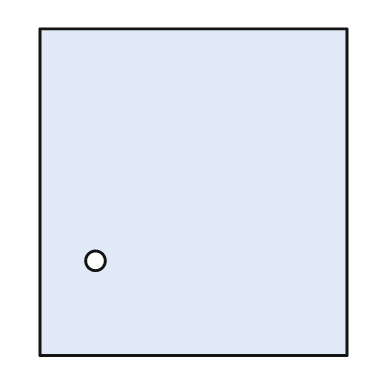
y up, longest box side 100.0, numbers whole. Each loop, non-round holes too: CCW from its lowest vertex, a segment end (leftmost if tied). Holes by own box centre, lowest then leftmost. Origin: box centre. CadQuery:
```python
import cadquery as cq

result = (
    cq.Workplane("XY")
    .moveTo(-47.0, -50.0)
    .lineTo(47.0, -50.0)
    .lineTo(47.0, 50.0)
    .lineTo(-47.0, 50.0)
    .close()
    .moveTo(-30.0, -21.0)
    .circle(3.0)
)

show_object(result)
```